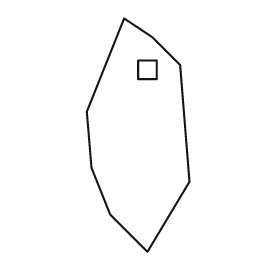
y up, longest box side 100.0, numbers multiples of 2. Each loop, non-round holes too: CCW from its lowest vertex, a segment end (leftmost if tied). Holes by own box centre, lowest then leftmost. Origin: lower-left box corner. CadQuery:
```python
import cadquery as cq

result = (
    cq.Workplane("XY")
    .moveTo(26.0, 0.0)
    .lineTo(44.0, 30.0)
    .lineTo(40.0, 80.0)
    .lineTo(28.0, 92.0)
    .lineTo(16.0, 100.0)
    .lineTo(0.0, 60.0)
    .lineTo(2.0, 36.0)
    .lineTo(10.0, 16.0)
    .close()
    .moveTo(22.0, 74.0)
    .lineTo(30.0, 74.0)
    .lineTo(30.0, 82.0)
    .lineTo(22.0, 82.0)
    .close()
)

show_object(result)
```